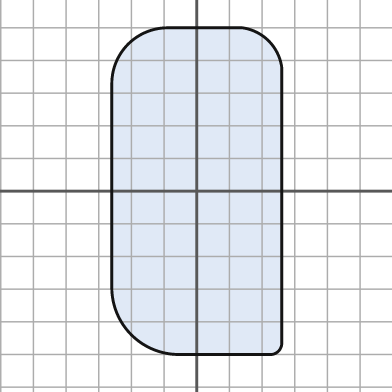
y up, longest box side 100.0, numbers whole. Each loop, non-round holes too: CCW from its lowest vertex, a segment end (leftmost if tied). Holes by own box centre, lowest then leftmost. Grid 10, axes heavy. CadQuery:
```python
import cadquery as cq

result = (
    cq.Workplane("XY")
    .moveTo(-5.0, -50.0)
    .lineTo(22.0, -50.0)
    .threePointArc((25.0, -49.0), (26.0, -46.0))
    .lineTo(26.0, 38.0)
    .threePointArc((22.0, 46.0), (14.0, 50.0))
    .lineTo(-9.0, 50.0)
    .threePointArc((-21.0, 45.0), (-26.0, 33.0))
    .lineTo(-26.0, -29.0)
    .threePointArc((-20.0, -44.0), (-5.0, -50.0))
    .close()
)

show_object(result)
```